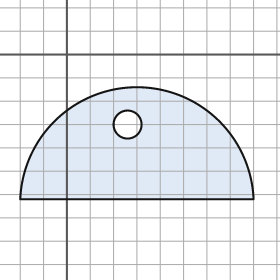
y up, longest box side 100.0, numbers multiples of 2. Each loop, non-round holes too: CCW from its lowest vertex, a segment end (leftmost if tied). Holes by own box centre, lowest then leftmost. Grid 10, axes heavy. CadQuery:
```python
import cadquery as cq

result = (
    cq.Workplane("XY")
    .moveTo(-20.0, -62.0)
    .lineTo(80.0, -62.0)
    .threePointArc((30.0, -14.0), (-20.0, -62.0))
    .close()
    .moveTo(26.0, -30.0)
    .circle(6.0)
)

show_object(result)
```